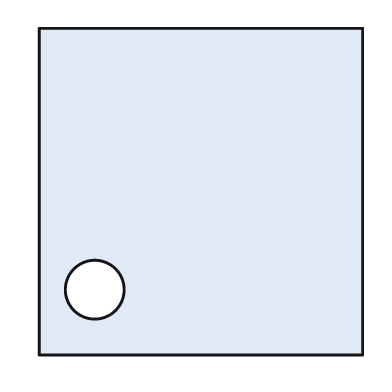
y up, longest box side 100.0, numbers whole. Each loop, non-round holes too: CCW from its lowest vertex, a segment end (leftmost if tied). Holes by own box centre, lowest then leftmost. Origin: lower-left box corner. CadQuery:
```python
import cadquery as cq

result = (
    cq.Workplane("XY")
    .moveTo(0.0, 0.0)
    .lineTo(99.0, 0.0)
    .lineTo(99.0, 100.0)
    .lineTo(0.0, 100.0)
    .close()
    .moveTo(17.0, 20.0)
    .circle(9.0)
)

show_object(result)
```